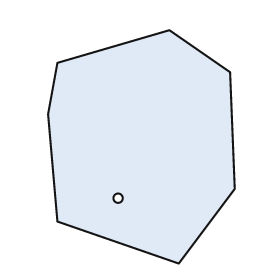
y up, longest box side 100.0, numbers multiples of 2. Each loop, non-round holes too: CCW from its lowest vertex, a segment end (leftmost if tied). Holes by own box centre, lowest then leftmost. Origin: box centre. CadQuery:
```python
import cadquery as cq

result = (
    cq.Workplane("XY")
    .moveTo(16.0, -50.0)
    .lineTo(40.0, -18.0)
    .lineTo(38.0, 32.0)
    .lineTo(12.0, 50.0)
    .lineTo(-36.0, 36.0)
    .lineTo(-40.0, 14.0)
    .lineTo(-36.0, -32.0)
    .close()
    .moveTo(-10.0, -22.0)
    .circle(2.0)
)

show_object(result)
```